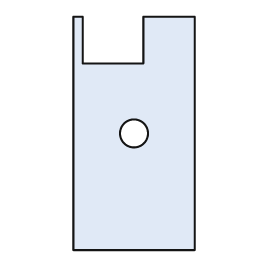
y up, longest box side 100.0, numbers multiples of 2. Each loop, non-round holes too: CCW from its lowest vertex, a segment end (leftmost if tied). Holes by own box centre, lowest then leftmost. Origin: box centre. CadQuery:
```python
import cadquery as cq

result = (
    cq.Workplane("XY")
    .moveTo(-26.0, -50.0)
    .lineTo(26.0, -50.0)
    .lineTo(26.0, 50.0)
    .lineTo(4.0, 50.0)
    .lineTo(4.0, 30.0)
    .lineTo(-22.0, 30.0)
    .lineTo(-22.0, 50.0)
    .lineTo(-26.0, 50.0)
    .close()
    .moveTo(0.0, 0.0)
    .circle(6.0)
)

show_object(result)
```